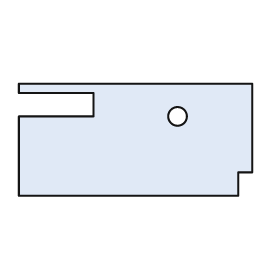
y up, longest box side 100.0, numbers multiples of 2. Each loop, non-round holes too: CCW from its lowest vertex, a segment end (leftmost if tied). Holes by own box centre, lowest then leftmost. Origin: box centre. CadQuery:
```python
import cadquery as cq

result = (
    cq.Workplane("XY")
    .moveTo(-50.0, -24.0)
    .lineTo(44.0, -24.0)
    .lineTo(44.0, -14.0)
    .lineTo(50.0, -14.0)
    .lineTo(50.0, 24.0)
    .lineTo(-50.0, 24.0)
    .lineTo(-50.0, 20.0)
    .lineTo(-18.0, 20.0)
    .lineTo(-18.0, 10.0)
    .lineTo(-50.0, 10.0)
    .close()
    .moveTo(18.0, 10.0)
    .circle(4.0)
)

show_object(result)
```